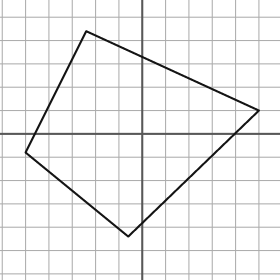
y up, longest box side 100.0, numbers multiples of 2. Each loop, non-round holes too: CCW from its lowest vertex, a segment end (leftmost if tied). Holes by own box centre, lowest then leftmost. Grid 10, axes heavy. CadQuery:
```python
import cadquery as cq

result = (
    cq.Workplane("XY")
    .moveTo(-6.0, -44.0)
    .lineTo(50.0, 10.0)
    .lineTo(-24.0, 44.0)
    .lineTo(-50.0, -8.0)
    .close()
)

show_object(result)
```